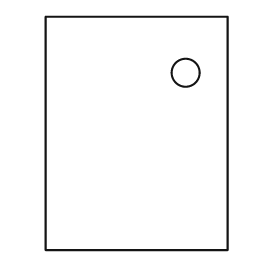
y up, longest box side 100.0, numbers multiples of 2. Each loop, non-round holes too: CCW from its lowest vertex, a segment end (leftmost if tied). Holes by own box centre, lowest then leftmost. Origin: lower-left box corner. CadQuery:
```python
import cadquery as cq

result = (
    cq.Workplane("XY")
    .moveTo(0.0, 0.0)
    .lineTo(78.0, 0.0)
    .lineTo(78.0, 100.0)
    .lineTo(0.0, 100.0)
    .close()
    .moveTo(60.0, 76.0)
    .circle(6.0)
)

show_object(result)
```